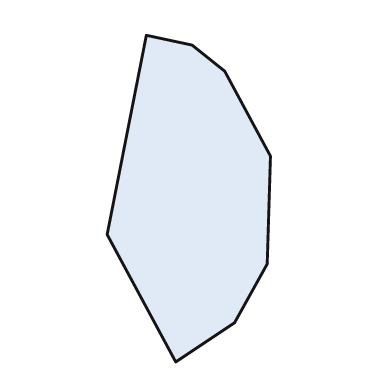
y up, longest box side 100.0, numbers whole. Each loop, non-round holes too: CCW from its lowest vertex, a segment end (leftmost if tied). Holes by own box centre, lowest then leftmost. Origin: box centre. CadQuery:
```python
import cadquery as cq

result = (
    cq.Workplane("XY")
    .moveTo(-4.0, -50.0)
    .lineTo(14.0, -38.0)
    .lineTo(24.0, -20.0)
    .lineTo(25.0, 13.0)
    .lineTo(11.0, 39.0)
    .lineTo(1.0, 47.0)
    .lineTo(-13.0, 50.0)
    .lineTo(-25.0, -11.0)
    .close()
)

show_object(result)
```